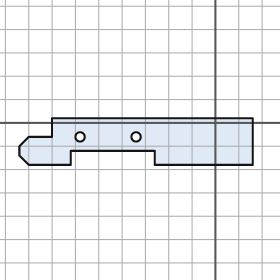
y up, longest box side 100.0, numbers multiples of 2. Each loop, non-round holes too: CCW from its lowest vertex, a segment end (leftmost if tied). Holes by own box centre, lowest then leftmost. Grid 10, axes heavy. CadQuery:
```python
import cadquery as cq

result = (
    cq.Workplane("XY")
    .moveTo(-80.0, -18.0)
    .lineTo(-62.0, -18.0)
    .lineTo(-62.0, -12.0)
    .lineTo(-26.0, -12.0)
    .lineTo(-26.0, -18.0)
    .lineTo(16.0, -18.0)
    .lineTo(16.0, 2.0)
    .lineTo(-70.0, 2.0)
    .lineTo(-70.0, -6.0)
    .lineTo(-80.0, -6.0)
    .lineTo(-84.0, -10.0)
    .lineTo(-84.0, -14.0)
    .close()
    .moveTo(-58.0, -6.0)
    .circle(2.0)
    .moveTo(-34.0, -6.0)
    .circle(2.0)
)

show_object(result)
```